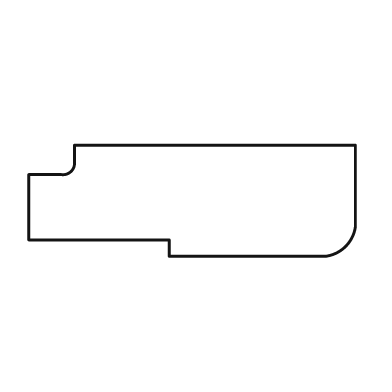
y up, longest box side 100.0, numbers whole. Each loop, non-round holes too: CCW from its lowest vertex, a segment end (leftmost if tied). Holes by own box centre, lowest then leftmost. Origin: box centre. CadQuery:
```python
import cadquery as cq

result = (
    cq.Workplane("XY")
    .moveTo(-7.0, -17.0)
    .lineTo(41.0, -17.0)
    .threePointArc((47.0, -14.0), (50.0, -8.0))
    .lineTo(50.0, 17.0)
    .lineTo(-36.0, 17.0)
    .lineTo(-36.0, 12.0)
    .threePointArc((-37.0, 9.0), (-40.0, 8.0))
    .lineTo(-50.0, 8.0)
    .lineTo(-50.0, -12.0)
    .lineTo(-7.0, -12.0)
    .close()
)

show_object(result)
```